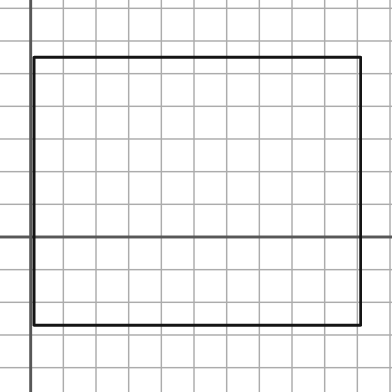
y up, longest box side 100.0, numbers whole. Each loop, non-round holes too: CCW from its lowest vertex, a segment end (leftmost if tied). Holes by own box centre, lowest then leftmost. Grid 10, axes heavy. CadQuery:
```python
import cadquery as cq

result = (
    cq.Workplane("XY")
    .moveTo(1.0, -27.0)
    .lineTo(101.0, -27.0)
    .lineTo(101.0, 55.0)
    .lineTo(1.0, 55.0)
    .close()
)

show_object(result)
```